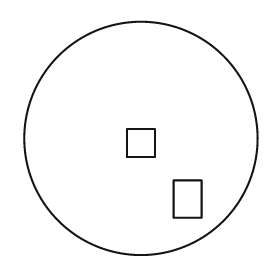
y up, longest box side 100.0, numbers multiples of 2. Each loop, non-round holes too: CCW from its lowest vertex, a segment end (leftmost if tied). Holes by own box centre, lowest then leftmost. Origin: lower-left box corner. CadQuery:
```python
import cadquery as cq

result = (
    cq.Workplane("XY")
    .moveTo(50.0, 50.0)
    .circle(50.0)
    .moveTo(64.0, 16.0)
    .lineTo(76.0, 16.0)
    .lineTo(76.0, 32.0)
    .lineTo(64.0, 32.0)
    .close()
    .moveTo(44.0, 42.0)
    .lineTo(56.0, 42.0)
    .lineTo(56.0, 54.0)
    .lineTo(44.0, 54.0)
    .close()
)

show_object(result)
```